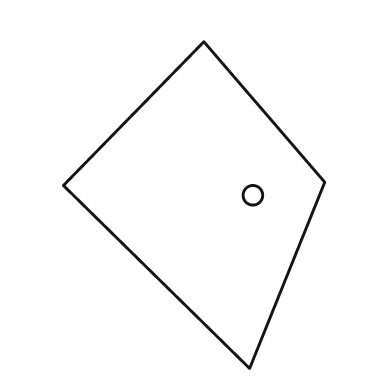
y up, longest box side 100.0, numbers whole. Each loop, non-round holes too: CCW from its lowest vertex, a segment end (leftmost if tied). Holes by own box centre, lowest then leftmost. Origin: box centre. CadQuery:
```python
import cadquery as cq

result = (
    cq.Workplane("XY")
    .moveTo(17.0, -50.0)
    .lineTo(40.0, 7.0)
    .lineTo(3.0, 50.0)
    .lineTo(-40.0, 6.0)
    .close()
    .moveTo(18.0, 3.0)
    .circle(3.0)
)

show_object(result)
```